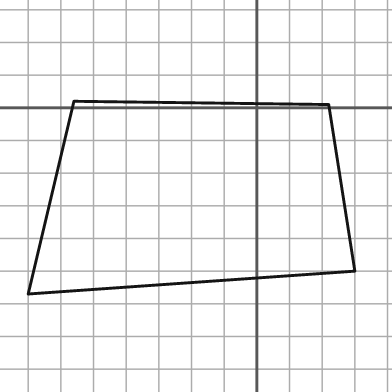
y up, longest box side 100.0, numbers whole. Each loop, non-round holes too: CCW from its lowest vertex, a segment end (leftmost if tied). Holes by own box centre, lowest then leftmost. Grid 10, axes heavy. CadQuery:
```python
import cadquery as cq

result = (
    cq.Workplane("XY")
    .moveTo(-70.0, -57.0)
    .lineTo(30.0, -50.0)
    .lineTo(22.0, 1.0)
    .lineTo(-56.0, 2.0)
    .close()
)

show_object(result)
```